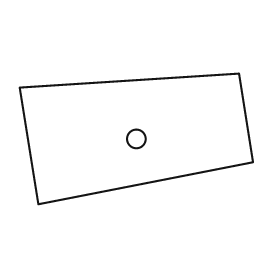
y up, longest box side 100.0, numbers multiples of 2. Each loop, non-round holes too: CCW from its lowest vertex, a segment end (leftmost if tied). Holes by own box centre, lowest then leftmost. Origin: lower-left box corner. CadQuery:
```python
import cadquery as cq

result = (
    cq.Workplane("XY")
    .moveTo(8.0, 0.0)
    .lineTo(100.0, 18.0)
    .lineTo(94.0, 56.0)
    .lineTo(0.0, 50.0)
    .close()
    .moveTo(50.0, 28.0)
    .circle(4.0)
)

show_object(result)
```